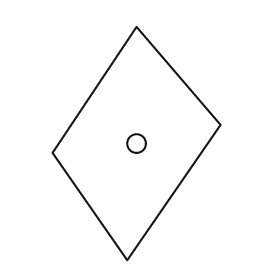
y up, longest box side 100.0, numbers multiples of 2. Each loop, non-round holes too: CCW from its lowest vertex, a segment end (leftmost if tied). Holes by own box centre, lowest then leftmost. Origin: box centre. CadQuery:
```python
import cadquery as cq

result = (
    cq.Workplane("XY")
    .moveTo(-4.0, -50.0)
    .lineTo(36.0, 8.0)
    .lineTo(0.0, 50.0)
    .lineTo(-36.0, -4.0)
    .close()
    .moveTo(0.0, 0.0)
    .circle(4.0)
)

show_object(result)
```